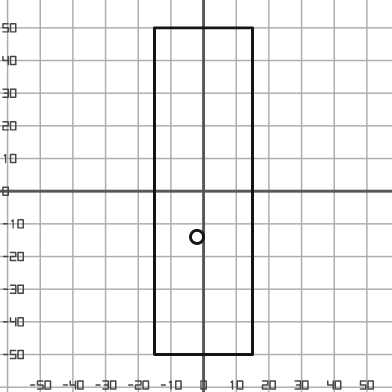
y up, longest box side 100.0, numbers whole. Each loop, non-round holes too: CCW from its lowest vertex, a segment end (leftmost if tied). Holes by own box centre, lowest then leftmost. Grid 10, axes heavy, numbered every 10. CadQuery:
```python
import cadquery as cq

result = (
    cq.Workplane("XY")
    .moveTo(-15.0, -50.0)
    .lineTo(15.0, -50.0)
    .lineTo(15.0, 50.0)
    .lineTo(-15.0, 50.0)
    .close()
    .moveTo(-2.0, -14.0)
    .circle(2.0)
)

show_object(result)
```